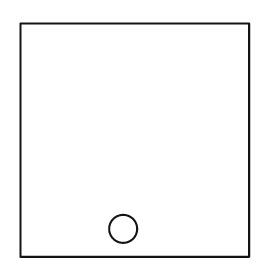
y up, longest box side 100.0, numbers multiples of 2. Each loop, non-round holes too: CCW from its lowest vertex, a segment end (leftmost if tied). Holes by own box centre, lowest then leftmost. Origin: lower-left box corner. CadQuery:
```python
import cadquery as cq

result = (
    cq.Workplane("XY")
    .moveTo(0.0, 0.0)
    .lineTo(98.0, 0.0)
    .lineTo(98.0, 100.0)
    .lineTo(0.0, 100.0)
    .close()
    .moveTo(44.0, 12.0)
    .circle(6.0)
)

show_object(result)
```